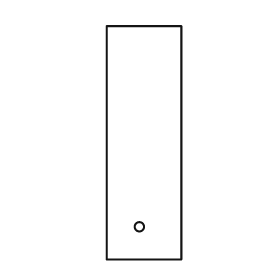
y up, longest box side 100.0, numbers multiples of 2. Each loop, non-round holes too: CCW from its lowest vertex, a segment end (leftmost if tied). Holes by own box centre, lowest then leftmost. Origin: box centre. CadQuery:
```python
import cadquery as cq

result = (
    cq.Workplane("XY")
    .moveTo(-16.0, -50.0)
    .lineTo(16.0, -50.0)
    .lineTo(16.0, 50.0)
    .lineTo(-16.0, 50.0)
    .close()
    .moveTo(-2.0, -36.0)
    .circle(2.0)
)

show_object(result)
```